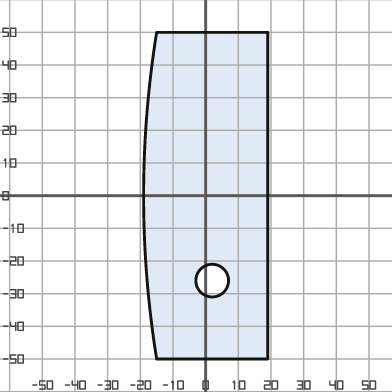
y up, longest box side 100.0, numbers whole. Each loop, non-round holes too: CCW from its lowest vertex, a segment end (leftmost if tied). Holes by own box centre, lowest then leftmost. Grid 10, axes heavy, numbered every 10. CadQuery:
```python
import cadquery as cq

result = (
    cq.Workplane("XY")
    .moveTo(-15.0, -50.0)
    .lineTo(19.0, -50.0)
    .lineTo(19.0, 50.0)
    .lineTo(-15.0, 50.0)
    .threePointArc((-19.0, 0.0), (-15.0, -50.0))
    .close()
    .moveTo(2.0, -26.0)
    .circle(5.0)
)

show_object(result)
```